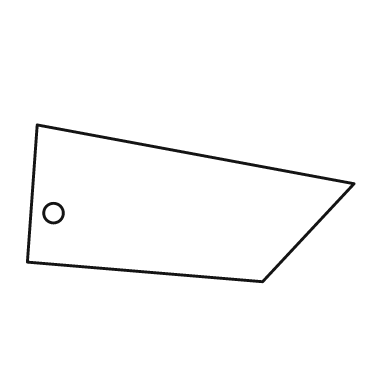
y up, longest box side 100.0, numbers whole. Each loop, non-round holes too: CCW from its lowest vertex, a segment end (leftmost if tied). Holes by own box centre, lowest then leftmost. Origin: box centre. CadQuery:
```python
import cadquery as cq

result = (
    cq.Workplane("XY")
    .moveTo(22.0, -24.0)
    .lineTo(50.0, 6.0)
    .lineTo(-47.0, 24.0)
    .lineTo(-50.0, -18.0)
    .close()
    .moveTo(-42.0, -3.0)
    .circle(3.0)
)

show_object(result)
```